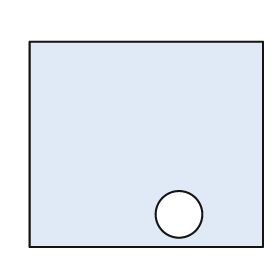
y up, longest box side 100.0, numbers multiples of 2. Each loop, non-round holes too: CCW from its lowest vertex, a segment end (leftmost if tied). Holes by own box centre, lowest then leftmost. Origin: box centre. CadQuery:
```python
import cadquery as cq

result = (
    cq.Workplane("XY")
    .moveTo(-50.0, -44.0)
    .lineTo(50.0, -44.0)
    .lineTo(50.0, 44.0)
    .lineTo(-50.0, 44.0)
    .close()
    .moveTo(14.0, -30.0)
    .circle(10.0)
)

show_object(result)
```